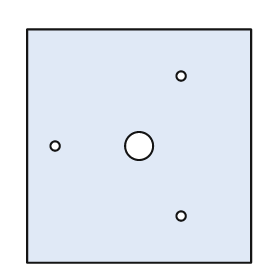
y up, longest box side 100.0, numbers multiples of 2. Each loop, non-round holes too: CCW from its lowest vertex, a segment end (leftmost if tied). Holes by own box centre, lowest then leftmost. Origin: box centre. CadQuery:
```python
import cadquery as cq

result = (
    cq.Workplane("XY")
    .moveTo(-48.0, -50.0)
    .lineTo(48.0, -50.0)
    .lineTo(48.0, 50.0)
    .lineTo(-48.0, 50.0)
    .close()
    .moveTo(18.0, -30.0)
    .circle(2.0)
    .moveTo(-36.0, 0.0)
    .circle(2.0)
    .moveTo(0.0, 0.0)
    .circle(6.0)
    .moveTo(18.0, 30.0)
    .circle(2.0)
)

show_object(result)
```